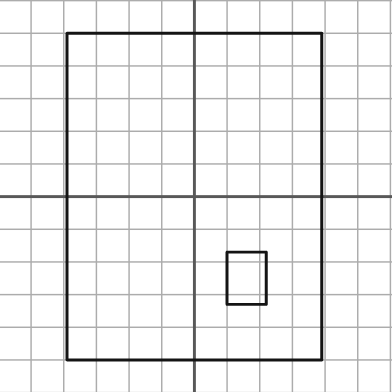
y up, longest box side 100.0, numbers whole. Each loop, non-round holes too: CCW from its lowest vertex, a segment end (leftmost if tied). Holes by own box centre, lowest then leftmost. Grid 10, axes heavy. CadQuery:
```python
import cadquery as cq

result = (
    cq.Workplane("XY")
    .moveTo(-39.0, -50.0)
    .lineTo(39.0, -50.0)
    .lineTo(39.0, 50.0)
    .lineTo(-39.0, 50.0)
    .close()
    .moveTo(10.0, -33.0)
    .lineTo(22.0, -33.0)
    .lineTo(22.0, -17.0)
    .lineTo(10.0, -17.0)
    .close()
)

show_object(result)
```